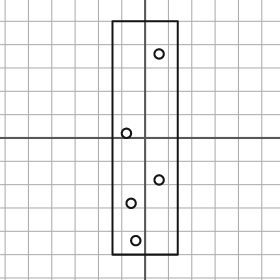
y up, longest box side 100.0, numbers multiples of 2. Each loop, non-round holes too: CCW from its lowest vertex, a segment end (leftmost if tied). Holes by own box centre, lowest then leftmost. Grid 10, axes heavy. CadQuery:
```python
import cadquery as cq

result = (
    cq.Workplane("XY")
    .moveTo(-14.0, -50.0)
    .lineTo(14.0, -50.0)
    .lineTo(14.0, 50.0)
    .lineTo(-14.0, 50.0)
    .close()
    .moveTo(-4.0, -44.0)
    .circle(2.0)
    .moveTo(-6.0, -28.0)
    .circle(2.0)
    .moveTo(6.0, -18.0)
    .circle(2.0)
    .moveTo(-8.0, 2.0)
    .circle(2.0)
    .moveTo(6.0, 36.0)
    .circle(2.0)
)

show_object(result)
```